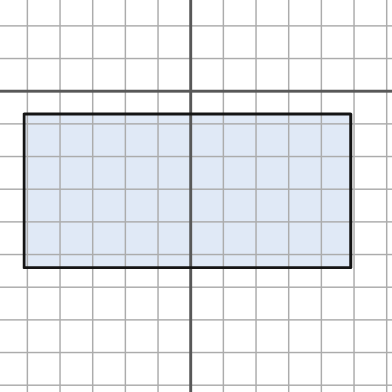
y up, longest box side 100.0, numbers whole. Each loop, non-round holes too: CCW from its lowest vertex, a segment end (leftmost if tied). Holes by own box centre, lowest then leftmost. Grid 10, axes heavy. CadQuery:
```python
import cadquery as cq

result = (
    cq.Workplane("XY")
    .moveTo(-51.0, -54.0)
    .lineTo(49.0, -54.0)
    .lineTo(49.0, -7.0)
    .lineTo(-51.0, -7.0)
    .close()
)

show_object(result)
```